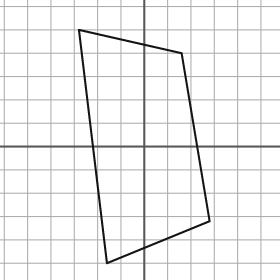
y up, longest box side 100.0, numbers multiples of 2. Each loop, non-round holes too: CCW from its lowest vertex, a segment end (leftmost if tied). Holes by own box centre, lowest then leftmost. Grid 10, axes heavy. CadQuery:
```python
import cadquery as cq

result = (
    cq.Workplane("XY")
    .moveTo(-16.0, -50.0)
    .lineTo(28.0, -32.0)
    .lineTo(16.0, 40.0)
    .lineTo(-28.0, 50.0)
    .close()
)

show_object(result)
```